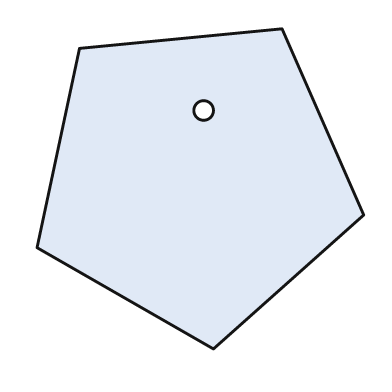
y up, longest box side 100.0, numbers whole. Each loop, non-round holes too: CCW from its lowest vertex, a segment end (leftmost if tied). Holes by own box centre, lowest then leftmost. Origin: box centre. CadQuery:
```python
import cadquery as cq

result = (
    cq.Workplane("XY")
    .moveTo(4.0, -49.0)
    .lineTo(50.0, -8.0)
    .lineTo(25.0, 49.0)
    .lineTo(-37.0, 43.0)
    .lineTo(-50.0, -18.0)
    .close()
    .moveTo(1.0, 24.0)
    .circle(3.0)
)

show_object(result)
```